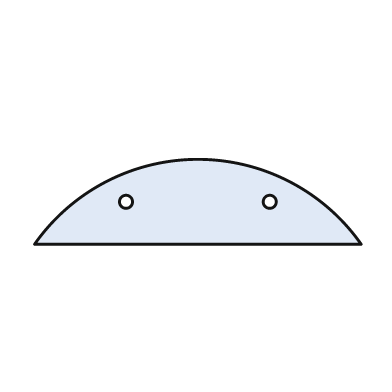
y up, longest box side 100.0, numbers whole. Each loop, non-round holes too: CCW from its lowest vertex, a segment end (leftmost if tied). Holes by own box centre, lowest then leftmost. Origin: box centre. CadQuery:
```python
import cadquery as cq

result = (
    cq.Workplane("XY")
    .moveTo(-50.0, -13.0)
    .lineTo(50.0, -13.0)
    .threePointArc((0.0, 13.0), (-50.0, -13.0))
    .close()
    .moveTo(-22.0, 0.0)
    .circle(2.0)
    .moveTo(22.0, 0.0)
    .circle(2.0)
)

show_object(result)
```